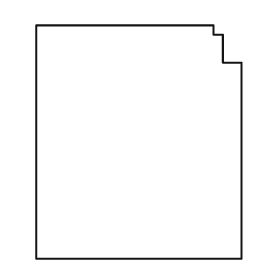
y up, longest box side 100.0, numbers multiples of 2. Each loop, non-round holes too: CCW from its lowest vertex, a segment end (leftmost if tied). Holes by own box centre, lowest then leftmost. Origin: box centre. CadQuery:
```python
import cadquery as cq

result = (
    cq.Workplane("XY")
    .moveTo(-44.0, -50.0)
    .lineTo(44.0, -50.0)
    .lineTo(44.0, 34.0)
    .lineTo(36.0, 34.0)
    .lineTo(36.0, 46.0)
    .lineTo(32.0, 46.0)
    .lineTo(32.0, 50.0)
    .lineTo(-44.0, 50.0)
    .close()
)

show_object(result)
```